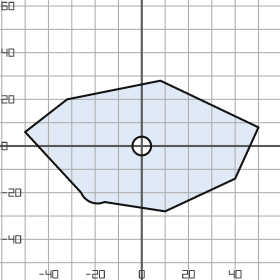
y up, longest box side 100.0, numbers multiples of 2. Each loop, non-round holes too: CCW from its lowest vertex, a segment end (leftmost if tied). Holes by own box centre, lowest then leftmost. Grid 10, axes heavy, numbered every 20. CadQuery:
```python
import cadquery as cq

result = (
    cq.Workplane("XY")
    .moveTo(10.0, -28.0)
    .lineTo(40.0, -14.0)
    .lineTo(50.0, 8.0)
    .lineTo(8.0, 28.0)
    .lineTo(-32.0, 20.0)
    .lineTo(-50.0, 6.0)
    .lineTo(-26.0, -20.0)
    .threePointArc((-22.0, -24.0), (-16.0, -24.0))
    .close()
    .moveTo(0.0, 0.0)
    .circle(4.0)
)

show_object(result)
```